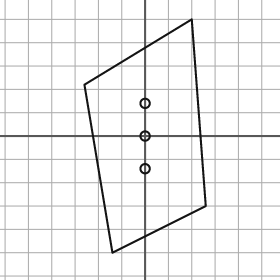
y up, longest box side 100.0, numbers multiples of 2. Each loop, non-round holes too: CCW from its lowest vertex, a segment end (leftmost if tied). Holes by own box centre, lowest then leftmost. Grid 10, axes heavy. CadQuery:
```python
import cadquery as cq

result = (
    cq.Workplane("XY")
    .moveTo(-14.0, -50.0)
    .lineTo(26.0, -30.0)
    .lineTo(20.0, 50.0)
    .lineTo(-26.0, 22.0)
    .close()
    .moveTo(0.0, -14.0)
    .circle(2.0)
    .moveTo(0.0, 0.0)
    .circle(2.0)
    .moveTo(0.0, 14.0)
    .circle(2.0)
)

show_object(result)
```